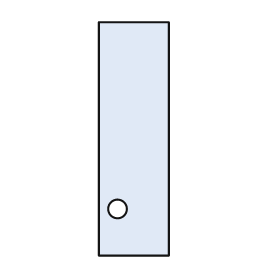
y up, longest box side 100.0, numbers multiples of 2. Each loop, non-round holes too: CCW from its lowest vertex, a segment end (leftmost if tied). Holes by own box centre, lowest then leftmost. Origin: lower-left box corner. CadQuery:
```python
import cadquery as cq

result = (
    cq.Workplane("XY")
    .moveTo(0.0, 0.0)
    .lineTo(30.0, 0.0)
    .lineTo(30.0, 100.0)
    .lineTo(0.0, 100.0)
    .close()
    .moveTo(8.0, 20.0)
    .circle(4.0)
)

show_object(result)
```